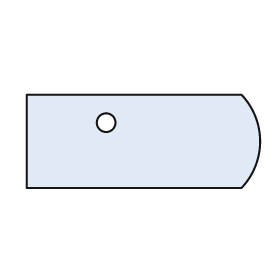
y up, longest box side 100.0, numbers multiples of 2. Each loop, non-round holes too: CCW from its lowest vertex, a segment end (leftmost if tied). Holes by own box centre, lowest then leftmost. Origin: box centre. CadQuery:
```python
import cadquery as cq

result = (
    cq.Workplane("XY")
    .moveTo(-50.0, -20.0)
    .lineTo(42.0, -20.0)
    .threePointArc((50.0, 0.0), (42.0, 20.0))
    .lineTo(-50.0, 20.0)
    .close()
    .moveTo(-16.0, 8.0)
    .circle(4.0)
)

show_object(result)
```